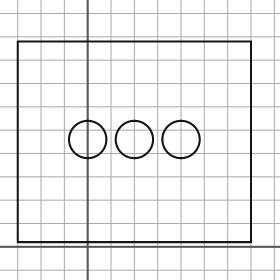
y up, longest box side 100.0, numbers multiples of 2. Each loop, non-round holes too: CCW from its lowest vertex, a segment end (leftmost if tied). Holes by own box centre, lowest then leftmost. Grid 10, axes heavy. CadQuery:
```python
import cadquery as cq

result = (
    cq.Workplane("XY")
    .moveTo(-30.0, 2.0)
    .lineTo(70.0, 2.0)
    .lineTo(70.0, 88.0)
    .lineTo(-30.0, 88.0)
    .close()
    .moveTo(0.0, 46.0)
    .circle(8.0)
    .moveTo(20.0, 46.0)
    .circle(8.0)
    .moveTo(40.0, 46.0)
    .circle(8.0)
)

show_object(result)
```